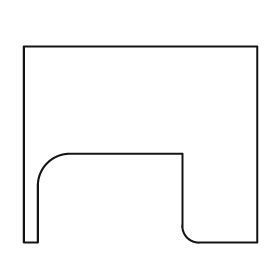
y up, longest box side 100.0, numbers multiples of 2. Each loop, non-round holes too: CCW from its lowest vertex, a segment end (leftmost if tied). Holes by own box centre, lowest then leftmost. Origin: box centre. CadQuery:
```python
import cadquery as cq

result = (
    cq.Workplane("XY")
    .moveTo(-50.0, -42.0)
    .lineTo(-44.0, -42.0)
    .lineTo(-44.0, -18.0)
    .threePointArc((-40.0, -8.0), (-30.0, -4.0))
    .lineTo(18.0, -4.0)
    .lineTo(18.0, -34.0)
    .threePointArc((20.0, -40.0), (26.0, -42.0))
    .lineTo(50.0, -42.0)
    .lineTo(50.0, 42.0)
    .lineTo(-50.0, 42.0)
    .close()
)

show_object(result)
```